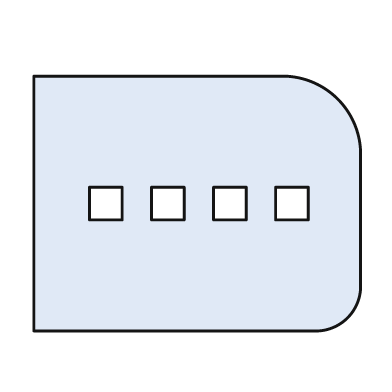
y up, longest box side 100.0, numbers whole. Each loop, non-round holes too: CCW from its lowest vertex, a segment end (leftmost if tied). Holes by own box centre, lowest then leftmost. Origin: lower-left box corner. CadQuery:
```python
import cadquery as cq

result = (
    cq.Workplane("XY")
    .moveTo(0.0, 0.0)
    .lineTo(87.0, 0.0)
    .threePointArc((96.0, 4.0), (100.0, 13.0))
    .lineTo(100.0, 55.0)
    .threePointArc((93.0, 71.0), (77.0, 78.0))
    .lineTo(0.0, 78.0)
    .close()
    .moveTo(17.0, 34.0)
    .lineTo(27.0, 34.0)
    .lineTo(27.0, 44.0)
    .lineTo(17.0, 44.0)
    .close()
    .moveTo(36.0, 34.0)
    .lineTo(46.0, 34.0)
    .lineTo(46.0, 44.0)
    .lineTo(36.0, 44.0)
    .close()
    .moveTo(55.0, 34.0)
    .lineTo(65.0, 34.0)
    .lineTo(65.0, 44.0)
    .lineTo(55.0, 44.0)
    .close()
    .moveTo(74.0, 34.0)
    .lineTo(84.0, 34.0)
    .lineTo(84.0, 44.0)
    .lineTo(74.0, 44.0)
    .close()
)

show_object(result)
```